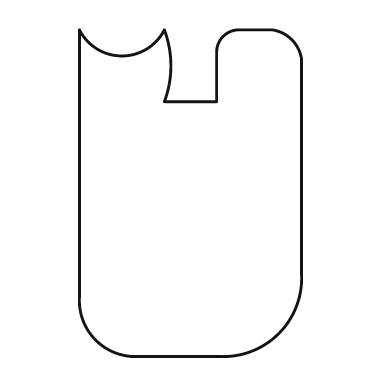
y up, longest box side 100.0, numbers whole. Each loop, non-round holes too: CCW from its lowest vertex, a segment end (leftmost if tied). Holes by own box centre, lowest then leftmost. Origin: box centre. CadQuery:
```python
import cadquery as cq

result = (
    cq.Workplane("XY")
    .moveTo(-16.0, -50.0)
    .lineTo(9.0, -50.0)
    .threePointArc((27.0, -43.0), (34.0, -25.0))
    .lineTo(34.0, 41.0)
    .threePointArc((31.0, 47.0), (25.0, 50.0))
    .lineTo(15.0, 50.0)
    .threePointArc((10.0, 48.0), (8.0, 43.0))
    .lineTo(8.0, 28.0)
    .lineTo(-8.0, 28.0)
    .threePointArc((-6.0, 39.0), (-8.0, 50.0))
    .threePointArc((-21.0, 42.0), (-34.0, 50.0))
    .lineTo(-34.0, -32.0)
    .threePointArc((-29.0, -45.0), (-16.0, -50.0))
    .close()
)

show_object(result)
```